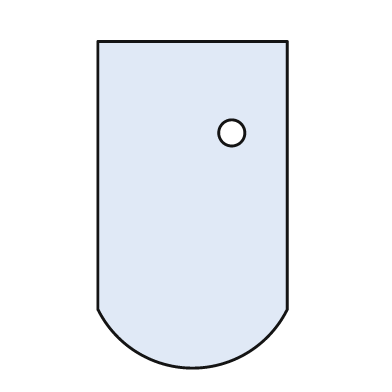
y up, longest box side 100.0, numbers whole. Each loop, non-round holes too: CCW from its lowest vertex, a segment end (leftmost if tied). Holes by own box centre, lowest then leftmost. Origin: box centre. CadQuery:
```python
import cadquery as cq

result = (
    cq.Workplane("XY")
    .moveTo(-29.0, -32.0)
    .threePointArc((0.0, -50.0), (29.0, -32.0))
    .lineTo(29.0, 50.0)
    .lineTo(-29.0, 50.0)
    .close()
    .moveTo(12.0, 22.0)
    .circle(4.0)
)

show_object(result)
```